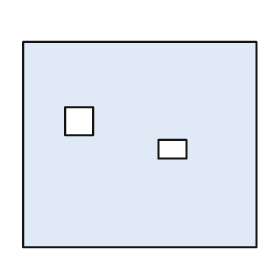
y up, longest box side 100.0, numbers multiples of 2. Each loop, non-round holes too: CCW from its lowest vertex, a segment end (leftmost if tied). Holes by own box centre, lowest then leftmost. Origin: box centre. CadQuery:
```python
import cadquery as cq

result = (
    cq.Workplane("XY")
    .moveTo(-50.0, -44.0)
    .lineTo(50.0, -44.0)
    .lineTo(50.0, 44.0)
    .lineTo(-50.0, 44.0)
    .close()
    .moveTo(8.0, -6.0)
    .lineTo(20.0, -6.0)
    .lineTo(20.0, 2.0)
    .lineTo(8.0, 2.0)
    .close()
    .moveTo(-32.0, 4.0)
    .lineTo(-20.0, 4.0)
    .lineTo(-20.0, 16.0)
    .lineTo(-32.0, 16.0)
    .close()
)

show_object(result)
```